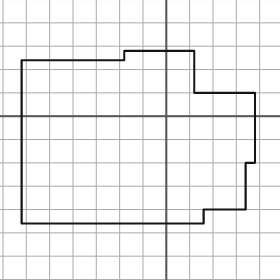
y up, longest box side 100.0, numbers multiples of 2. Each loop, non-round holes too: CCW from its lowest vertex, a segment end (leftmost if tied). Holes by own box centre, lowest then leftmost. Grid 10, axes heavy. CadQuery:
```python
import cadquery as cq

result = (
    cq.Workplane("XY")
    .moveTo(-62.0, -46.0)
    .lineTo(16.0, -46.0)
    .lineTo(16.0, -40.0)
    .lineTo(34.0, -40.0)
    .lineTo(34.0, -20.0)
    .lineTo(38.0, -20.0)
    .lineTo(38.0, 10.0)
    .lineTo(12.0, 10.0)
    .lineTo(12.0, 28.0)
    .lineTo(-18.0, 28.0)
    .lineTo(-18.0, 24.0)
    .lineTo(-62.0, 24.0)
    .close()
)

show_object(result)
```